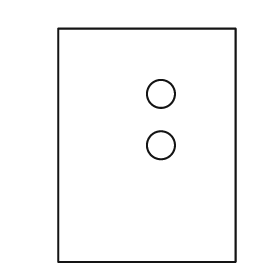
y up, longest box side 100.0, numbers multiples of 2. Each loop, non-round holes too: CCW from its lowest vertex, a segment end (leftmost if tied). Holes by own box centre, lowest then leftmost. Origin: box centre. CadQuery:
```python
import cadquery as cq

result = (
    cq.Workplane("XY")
    .moveTo(-38.0, -50.0)
    .lineTo(38.0, -50.0)
    .lineTo(38.0, 50.0)
    .lineTo(-38.0, 50.0)
    .close()
    .moveTo(6.0, 0.0)
    .circle(6.0)
    .moveTo(6.0, 22.0)
    .circle(6.0)
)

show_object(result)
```